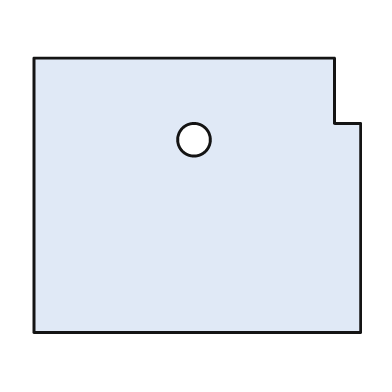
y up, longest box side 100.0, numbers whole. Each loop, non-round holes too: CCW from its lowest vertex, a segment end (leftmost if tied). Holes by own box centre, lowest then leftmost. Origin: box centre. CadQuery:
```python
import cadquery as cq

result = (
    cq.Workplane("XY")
    .moveTo(-50.0, -42.0)
    .lineTo(50.0, -42.0)
    .lineTo(50.0, 22.0)
    .lineTo(42.0, 22.0)
    .lineTo(42.0, 42.0)
    .lineTo(-50.0, 42.0)
    .close()
    .moveTo(-1.0, 17.0)
    .circle(5.0)
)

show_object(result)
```